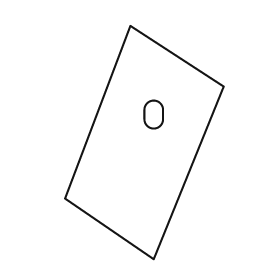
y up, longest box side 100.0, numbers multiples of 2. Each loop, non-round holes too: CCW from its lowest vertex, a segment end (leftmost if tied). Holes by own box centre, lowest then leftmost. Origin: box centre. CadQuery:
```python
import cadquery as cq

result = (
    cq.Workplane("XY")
    .moveTo(4.0, -50.0)
    .lineTo(34.0, 24.0)
    .lineTo(-6.0, 50.0)
    .lineTo(-34.0, -24.0)
    .close()
    .moveTo(0.0, 10.0)
    .threePointArc((4.0, 6.0), (8.0, 10.0))
    .lineTo(8.0, 14.0)
    .threePointArc((4.0, 18.0), (0.0, 14.0))
    .close()
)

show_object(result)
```